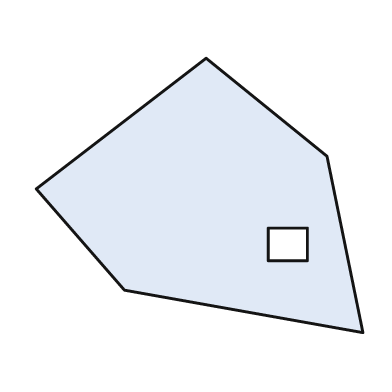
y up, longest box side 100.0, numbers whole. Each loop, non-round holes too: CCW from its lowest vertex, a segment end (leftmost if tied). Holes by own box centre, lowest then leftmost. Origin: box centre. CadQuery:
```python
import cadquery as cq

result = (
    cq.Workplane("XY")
    .moveTo(50.0, -42.0)
    .lineTo(39.0, 12.0)
    .lineTo(2.0, 42.0)
    .lineTo(-50.0, 2.0)
    .lineTo(-23.0, -29.0)
    .close()
    .moveTo(21.0, -20.0)
    .lineTo(33.0, -20.0)
    .lineTo(33.0, -10.0)
    .lineTo(21.0, -10.0)
    .close()
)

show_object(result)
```